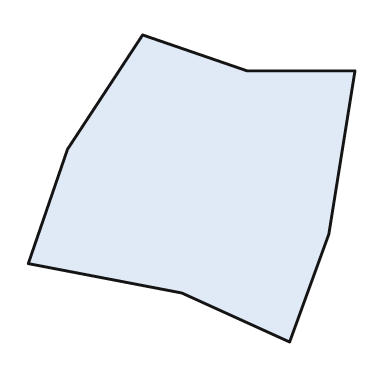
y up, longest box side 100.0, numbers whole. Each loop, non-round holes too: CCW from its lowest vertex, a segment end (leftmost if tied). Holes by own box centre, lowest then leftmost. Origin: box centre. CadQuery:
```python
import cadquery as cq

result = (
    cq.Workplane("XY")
    .moveTo(30.0, -47.0)
    .lineTo(42.0, -14.0)
    .lineTo(50.0, 36.0)
    .lineTo(17.0, 36.0)
    .lineTo(-15.0, 47.0)
    .lineTo(-38.0, 12.0)
    .lineTo(-50.0, -23.0)
    .lineTo(-3.0, -32.0)
    .close()
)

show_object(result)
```